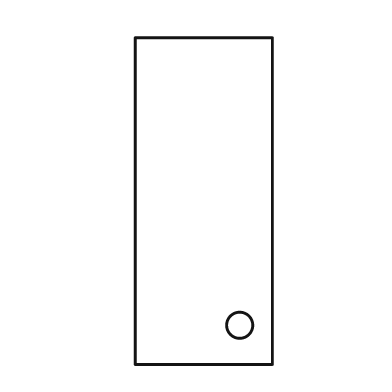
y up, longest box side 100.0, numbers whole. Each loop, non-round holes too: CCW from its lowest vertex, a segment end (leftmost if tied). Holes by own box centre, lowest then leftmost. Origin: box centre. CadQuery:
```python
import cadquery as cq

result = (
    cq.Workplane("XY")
    .moveTo(-21.0, -50.0)
    .lineTo(21.0, -50.0)
    .lineTo(21.0, 50.0)
    .lineTo(-21.0, 50.0)
    .close()
    .moveTo(11.0, -38.0)
    .circle(4.0)
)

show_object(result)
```